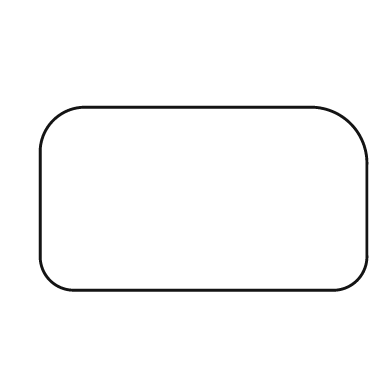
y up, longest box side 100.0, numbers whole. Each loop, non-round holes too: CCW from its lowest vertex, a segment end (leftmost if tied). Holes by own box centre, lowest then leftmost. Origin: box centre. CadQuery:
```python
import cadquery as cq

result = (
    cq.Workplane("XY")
    .moveTo(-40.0, -28.0)
    .lineTo(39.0, -28.0)
    .threePointArc((47.0, -25.0), (50.0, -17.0))
    .lineTo(50.0, 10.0)
    .threePointArc((45.0, 23.0), (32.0, 28.0))
    .lineTo(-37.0, 28.0)
    .threePointArc((-46.0, 24.0), (-50.0, 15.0))
    .lineTo(-50.0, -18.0)
    .threePointArc((-47.0, -25.0), (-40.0, -28.0))
    .close()
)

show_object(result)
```